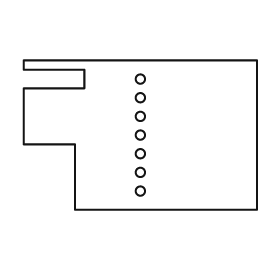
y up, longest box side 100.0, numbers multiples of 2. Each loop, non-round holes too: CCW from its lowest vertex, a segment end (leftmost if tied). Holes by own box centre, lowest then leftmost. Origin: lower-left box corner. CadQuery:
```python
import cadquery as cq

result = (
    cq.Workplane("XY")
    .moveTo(22.0, 0.0)
    .lineTo(100.0, 0.0)
    .lineTo(100.0, 64.0)
    .lineTo(0.0, 64.0)
    .lineTo(0.0, 60.0)
    .lineTo(26.0, 60.0)
    .lineTo(26.0, 52.0)
    .lineTo(0.0, 52.0)
    .lineTo(0.0, 28.0)
    .lineTo(22.0, 28.0)
    .close()
    .moveTo(50.0, 8.0)
    .circle(2.0)
    .moveTo(50.0, 16.0)
    .circle(2.0)
    .moveTo(50.0, 24.0)
    .circle(2.0)
    .moveTo(50.0, 32.0)
    .circle(2.0)
    .moveTo(50.0, 40.0)
    .circle(2.0)
    .moveTo(50.0, 48.0)
    .circle(2.0)
    .moveTo(50.0, 56.0)
    .circle(2.0)
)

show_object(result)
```